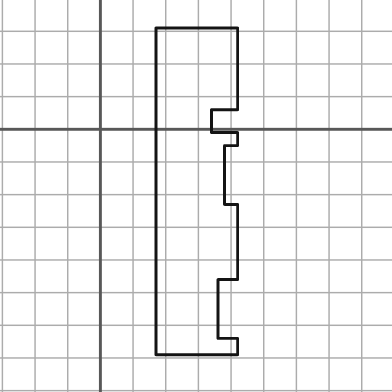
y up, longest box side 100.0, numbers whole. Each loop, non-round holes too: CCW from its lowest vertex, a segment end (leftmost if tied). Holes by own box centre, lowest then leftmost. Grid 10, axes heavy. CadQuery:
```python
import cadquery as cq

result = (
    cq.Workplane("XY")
    .moveTo(17.0, -69.0)
    .lineTo(42.0, -69.0)
    .lineTo(42.0, -64.0)
    .lineTo(36.0, -64.0)
    .lineTo(36.0, -46.0)
    .lineTo(42.0, -46.0)
    .lineTo(42.0, -23.0)
    .lineTo(38.0, -23.0)
    .lineTo(38.0, -5.0)
    .lineTo(42.0, -5.0)
    .lineTo(42.0, -1.0)
    .lineTo(34.0, -1.0)
    .lineTo(34.0, 6.0)
    .lineTo(42.0, 6.0)
    .lineTo(42.0, 31.0)
    .lineTo(17.0, 31.0)
    .close()
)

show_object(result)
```